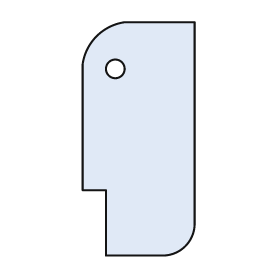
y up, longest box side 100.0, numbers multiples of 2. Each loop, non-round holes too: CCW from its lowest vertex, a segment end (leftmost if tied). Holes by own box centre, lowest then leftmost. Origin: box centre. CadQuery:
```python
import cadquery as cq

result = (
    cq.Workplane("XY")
    .moveTo(-14.0, -50.0)
    .lineTo(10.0, -50.0)
    .threePointArc((20.0, -46.0), (24.0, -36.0))
    .lineTo(24.0, 50.0)
    .lineTo(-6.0, 50.0)
    .threePointArc((-18.0, 44.0), (-24.0, 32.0))
    .lineTo(-24.0, -22.0)
    .lineTo(-14.0, -22.0)
    .close()
    .moveTo(-10.0, 30.0)
    .circle(4.0)
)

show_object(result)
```